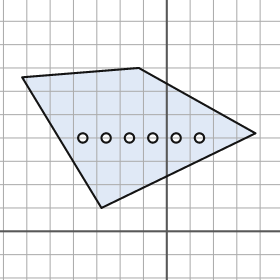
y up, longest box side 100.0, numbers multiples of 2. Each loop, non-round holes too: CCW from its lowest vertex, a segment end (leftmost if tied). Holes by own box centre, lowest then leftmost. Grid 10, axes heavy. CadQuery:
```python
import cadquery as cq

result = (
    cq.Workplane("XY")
    .moveTo(-28.0, 10.0)
    .lineTo(38.0, 42.0)
    .lineTo(-12.0, 70.0)
    .lineTo(-62.0, 66.0)
    .close()
    .moveTo(-36.0, 40.0)
    .circle(2.0)
    .moveTo(-26.0, 40.0)
    .circle(2.0)
    .moveTo(-16.0, 40.0)
    .circle(2.0)
    .moveTo(-6.0, 40.0)
    .circle(2.0)
    .moveTo(4.0, 40.0)
    .circle(2.0)
    .moveTo(14.0, 40.0)
    .circle(2.0)
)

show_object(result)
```